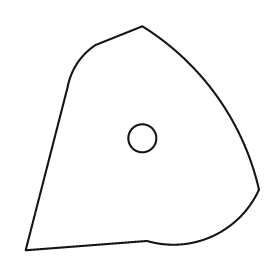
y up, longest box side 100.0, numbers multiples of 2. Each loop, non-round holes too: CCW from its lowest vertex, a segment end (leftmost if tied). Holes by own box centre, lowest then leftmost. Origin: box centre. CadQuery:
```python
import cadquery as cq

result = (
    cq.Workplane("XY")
    .moveTo(-50.0, -48.0)
    .lineTo(2.0, -44.0)
    .threePointArc((30.0, -42.0), (50.0, -22.0))
    .threePointArc((32.0, 18.0), (0.0, 48.0))
    .lineTo(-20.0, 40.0)
    .threePointArc((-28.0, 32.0), (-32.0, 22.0))
    .close()
    .moveTo(0.0, 0.0)
    .circle(6.0)
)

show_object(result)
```